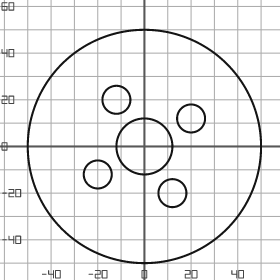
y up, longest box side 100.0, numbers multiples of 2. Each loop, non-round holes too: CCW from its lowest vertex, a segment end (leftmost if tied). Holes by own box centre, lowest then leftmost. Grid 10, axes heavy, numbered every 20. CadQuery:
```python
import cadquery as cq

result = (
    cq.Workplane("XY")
    .moveTo(0.0, 0.0)
    .circle(50.0)
    .moveTo(12.0, -20.0)
    .circle(6.0)
    .moveTo(-20.0, -12.0)
    .circle(6.0)
    .moveTo(0.0, 0.0)
    .circle(12.0)
    .moveTo(20.0, 12.0)
    .circle(6.0)
    .moveTo(-12.0, 20.0)
    .circle(6.0)
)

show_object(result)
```